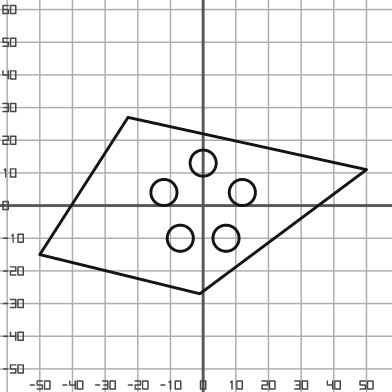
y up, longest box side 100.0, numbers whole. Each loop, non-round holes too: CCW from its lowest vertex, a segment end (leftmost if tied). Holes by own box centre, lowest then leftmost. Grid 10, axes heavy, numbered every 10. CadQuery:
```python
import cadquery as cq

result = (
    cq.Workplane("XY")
    .moveTo(-1.0, -27.0)
    .lineTo(50.0, 11.0)
    .lineTo(-23.0, 27.0)
    .lineTo(-50.0, -15.0)
    .close()
    .moveTo(-7.0, -10.0)
    .circle(4.0)
    .moveTo(7.0, -10.0)
    .circle(4.0)
    .moveTo(-12.0, 4.0)
    .circle(4.0)
    .moveTo(12.0, 4.0)
    .circle(4.0)
    .moveTo(0.0, 13.0)
    .circle(4.0)
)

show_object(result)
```